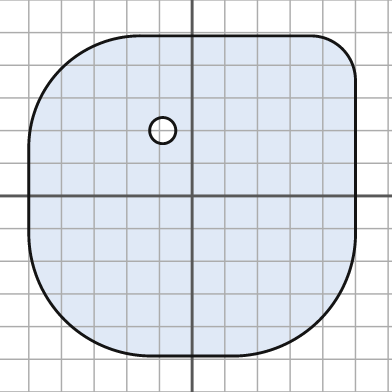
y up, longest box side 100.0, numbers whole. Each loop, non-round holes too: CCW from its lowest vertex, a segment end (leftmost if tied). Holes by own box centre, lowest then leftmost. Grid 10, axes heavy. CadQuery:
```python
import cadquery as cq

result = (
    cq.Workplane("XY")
    .moveTo(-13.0, -49.0)
    .lineTo(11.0, -49.0)
    .threePointArc((39.0, -38.0), (50.0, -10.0))
    .lineTo(50.0, 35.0)
    .threePointArc((46.0, 45.0), (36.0, 49.0))
    .lineTo(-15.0, 49.0)
    .threePointArc((-40.0, 39.0), (-50.0, 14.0))
    .lineTo(-50.0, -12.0)
    .threePointArc((-39.0, -38.0), (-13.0, -49.0))
    .close()
    .moveTo(-9.0, 20.0)
    .circle(4.0)
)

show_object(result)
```